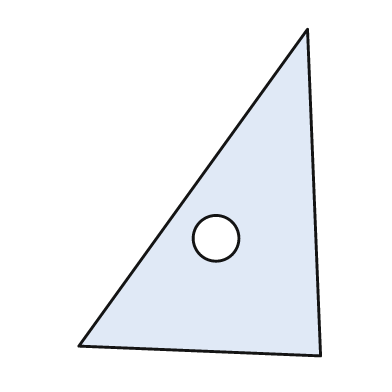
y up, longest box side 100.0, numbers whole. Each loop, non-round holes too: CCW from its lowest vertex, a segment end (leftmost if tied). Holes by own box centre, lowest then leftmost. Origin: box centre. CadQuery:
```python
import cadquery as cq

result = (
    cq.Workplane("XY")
    .moveTo(37.0, -50.0)
    .lineTo(33.0, 50.0)
    .lineTo(-37.0, -47.0)
    .close()
    .moveTo(5.0, -14.0)
    .circle(7.0)
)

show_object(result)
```